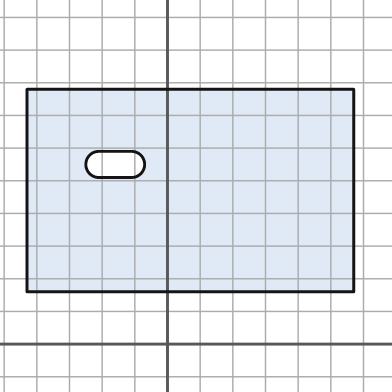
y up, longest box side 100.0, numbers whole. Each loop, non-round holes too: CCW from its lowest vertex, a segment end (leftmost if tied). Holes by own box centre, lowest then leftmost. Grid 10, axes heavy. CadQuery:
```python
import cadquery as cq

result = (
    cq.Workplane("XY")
    .moveTo(-43.0, 16.0)
    .lineTo(57.0, 16.0)
    .lineTo(57.0, 78.0)
    .lineTo(-43.0, 78.0)
    .close()
    .moveTo(-21.0, 51.0)
    .lineTo(-11.0, 51.0)
    .threePointArc((-7.0, 55.0), (-11.0, 59.0))
    .lineTo(-21.0, 59.0)
    .threePointArc((-25.0, 55.0), (-21.0, 51.0))
    .close()
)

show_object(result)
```